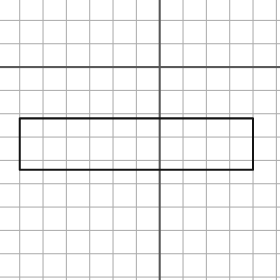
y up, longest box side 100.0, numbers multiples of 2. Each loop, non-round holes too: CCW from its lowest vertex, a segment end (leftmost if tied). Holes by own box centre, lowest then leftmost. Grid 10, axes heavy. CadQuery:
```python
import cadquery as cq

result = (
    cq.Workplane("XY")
    .moveTo(-60.0, -44.0)
    .lineTo(40.0, -44.0)
    .lineTo(40.0, -22.0)
    .lineTo(-60.0, -22.0)
    .close()
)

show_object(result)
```